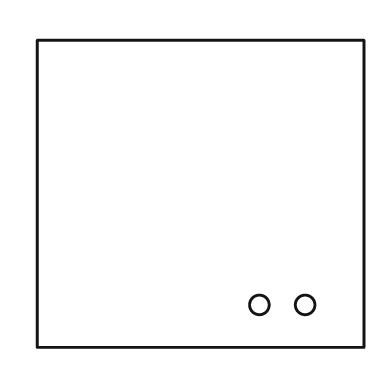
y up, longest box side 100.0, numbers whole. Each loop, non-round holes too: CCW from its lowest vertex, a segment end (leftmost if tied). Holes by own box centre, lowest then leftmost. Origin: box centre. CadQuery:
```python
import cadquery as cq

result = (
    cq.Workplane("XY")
    .moveTo(-50.0, -47.0)
    .lineTo(50.0, -47.0)
    .lineTo(50.0, 47.0)
    .lineTo(-50.0, 47.0)
    .close()
    .moveTo(18.0, -34.0)
    .circle(3.0)
    .moveTo(32.0, -34.0)
    .circle(3.0)
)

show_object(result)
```